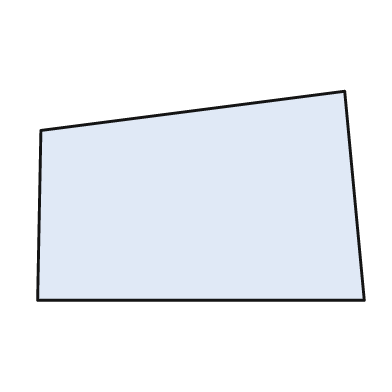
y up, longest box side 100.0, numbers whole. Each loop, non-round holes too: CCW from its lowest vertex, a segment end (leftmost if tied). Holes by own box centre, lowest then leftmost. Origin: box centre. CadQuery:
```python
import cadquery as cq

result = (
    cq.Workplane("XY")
    .moveTo(-50.0, -32.0)
    .lineTo(50.0, -32.0)
    .lineTo(44.0, 32.0)
    .lineTo(-49.0, 20.0)
    .close()
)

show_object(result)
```